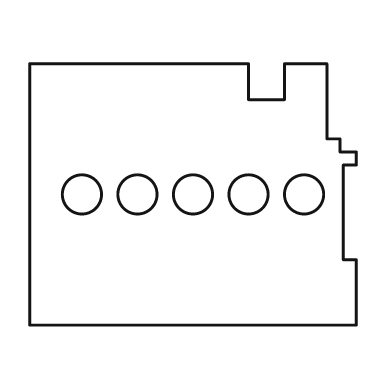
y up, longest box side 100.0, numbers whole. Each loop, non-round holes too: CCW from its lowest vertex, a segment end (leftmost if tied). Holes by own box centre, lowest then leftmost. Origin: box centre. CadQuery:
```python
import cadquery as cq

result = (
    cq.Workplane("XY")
    .moveTo(-50.0, -40.0)
    .lineTo(50.0, -40.0)
    .lineTo(50.0, -20.0)
    .lineTo(46.0, -20.0)
    .lineTo(46.0, 9.0)
    .lineTo(50.0, 9.0)
    .lineTo(50.0, 13.0)
    .lineTo(45.0, 13.0)
    .lineTo(45.0, 17.0)
    .lineTo(41.0, 17.0)
    .lineTo(41.0, 40.0)
    .lineTo(28.0, 40.0)
    .lineTo(28.0, 29.0)
    .lineTo(17.0, 29.0)
    .lineTo(17.0, 40.0)
    .lineTo(-50.0, 40.0)
    .close()
    .moveTo(-34.0, 0.0)
    .circle(6.0)
    .moveTo(-17.0, 0.0)
    .circle(6.0)
    .moveTo(0.0, 0.0)
    .circle(6.0)
    .moveTo(17.0, 0.0)
    .circle(6.0)
    .moveTo(34.0, 0.0)
    .circle(6.0)
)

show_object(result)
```